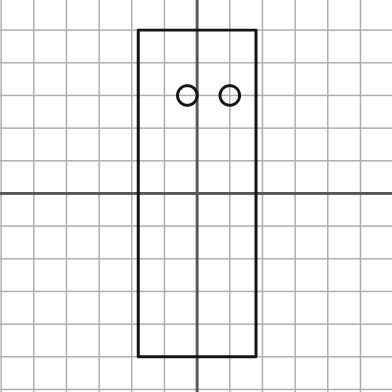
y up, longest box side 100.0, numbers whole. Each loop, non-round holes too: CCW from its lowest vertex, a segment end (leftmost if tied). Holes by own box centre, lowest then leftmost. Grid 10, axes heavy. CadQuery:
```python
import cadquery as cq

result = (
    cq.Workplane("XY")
    .moveTo(-18.0, -50.0)
    .lineTo(18.0, -50.0)
    .lineTo(18.0, 50.0)
    .lineTo(-18.0, 50.0)
    .close()
    .moveTo(-3.0, 30.0)
    .circle(3.0)
    .moveTo(10.0, 30.0)
    .circle(3.0)
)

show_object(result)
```